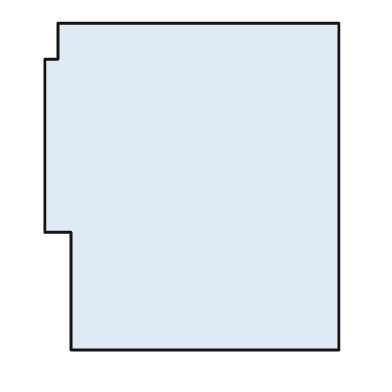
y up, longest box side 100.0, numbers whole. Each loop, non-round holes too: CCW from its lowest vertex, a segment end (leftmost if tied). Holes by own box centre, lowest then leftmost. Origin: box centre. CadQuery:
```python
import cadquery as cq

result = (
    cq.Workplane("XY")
    .moveTo(-37.0, -50.0)
    .lineTo(45.0, -50.0)
    .lineTo(45.0, 50.0)
    .lineTo(-41.0, 50.0)
    .lineTo(-41.0, 39.0)
    .lineTo(-45.0, 39.0)
    .lineTo(-45.0, -14.0)
    .lineTo(-37.0, -14.0)
    .close()
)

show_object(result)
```